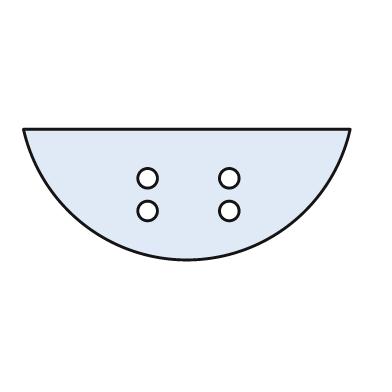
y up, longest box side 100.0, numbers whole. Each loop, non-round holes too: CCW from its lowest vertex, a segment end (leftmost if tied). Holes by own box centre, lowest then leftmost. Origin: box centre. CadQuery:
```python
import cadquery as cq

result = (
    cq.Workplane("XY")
    .moveTo(-50.0, 20.0)
    .threePointArc((0.0, -20.0), (50.0, 20.0))
    .close()
    .moveTo(-12.0, -5.0)
    .circle(3.0)
    .moveTo(13.0, -5.0)
    .circle(3.0)
    .moveTo(-12.0, 5.0)
    .circle(3.0)
    .moveTo(13.0, 5.0)
    .circle(3.0)
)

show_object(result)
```